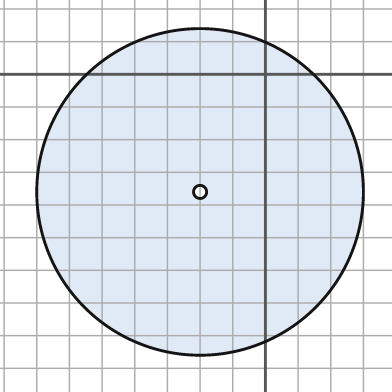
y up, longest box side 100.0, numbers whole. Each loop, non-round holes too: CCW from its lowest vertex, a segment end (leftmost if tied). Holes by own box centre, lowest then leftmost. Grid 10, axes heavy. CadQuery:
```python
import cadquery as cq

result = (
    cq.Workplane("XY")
    .moveTo(-20.0, -36.0)
    .circle(50.0)
    .moveTo(-20.0, -36.0)
    .circle(2.0)
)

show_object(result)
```